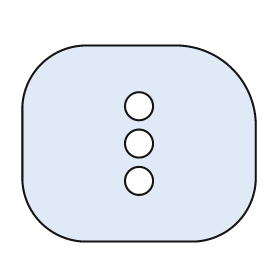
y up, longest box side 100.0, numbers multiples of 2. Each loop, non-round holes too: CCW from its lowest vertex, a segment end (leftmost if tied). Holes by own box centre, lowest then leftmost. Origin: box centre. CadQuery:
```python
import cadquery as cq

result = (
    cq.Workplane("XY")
    .moveTo(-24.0, -42.0)
    .lineTo(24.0, -42.0)
    .threePointArc((42.0, -34.0), (50.0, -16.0))
    .lineTo(50.0, 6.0)
    .threePointArc((40.0, 32.0), (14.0, 42.0))
    .lineTo(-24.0, 42.0)
    .threePointArc((-42.0, 34.0), (-50.0, 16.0))
    .lineTo(-50.0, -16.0)
    .threePointArc((-42.0, -34.0), (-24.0, -42.0))
    .close()
    .moveTo(0.0, -16.0)
    .circle(6.0)
    .moveTo(0.0, 0.0)
    .circle(6.0)
    .moveTo(0.0, 16.0)
    .circle(6.0)
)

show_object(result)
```